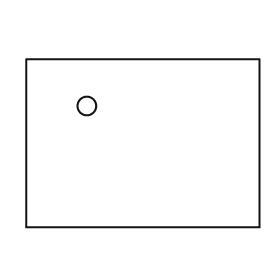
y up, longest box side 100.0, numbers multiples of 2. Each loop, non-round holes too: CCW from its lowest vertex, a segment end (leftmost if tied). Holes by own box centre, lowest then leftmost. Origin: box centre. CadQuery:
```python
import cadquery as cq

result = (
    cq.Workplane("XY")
    .moveTo(-50.0, -36.0)
    .lineTo(50.0, -36.0)
    .lineTo(50.0, 36.0)
    .lineTo(-50.0, 36.0)
    .close()
    .moveTo(-24.0, 16.0)
    .circle(4.0)
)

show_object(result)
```